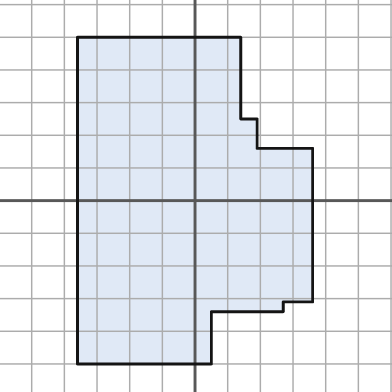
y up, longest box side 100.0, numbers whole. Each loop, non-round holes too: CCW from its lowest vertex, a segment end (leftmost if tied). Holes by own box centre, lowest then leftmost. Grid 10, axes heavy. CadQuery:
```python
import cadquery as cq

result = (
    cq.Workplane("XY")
    .moveTo(-36.0, -50.0)
    .lineTo(5.0, -50.0)
    .lineTo(5.0, -34.0)
    .lineTo(27.0, -34.0)
    .lineTo(27.0, -31.0)
    .lineTo(36.0, -31.0)
    .lineTo(36.0, 16.0)
    .lineTo(19.0, 16.0)
    .lineTo(19.0, 25.0)
    .lineTo(14.0, 25.0)
    .lineTo(14.0, 50.0)
    .lineTo(-36.0, 50.0)
    .close()
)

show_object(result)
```